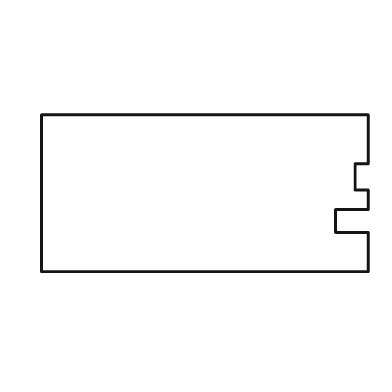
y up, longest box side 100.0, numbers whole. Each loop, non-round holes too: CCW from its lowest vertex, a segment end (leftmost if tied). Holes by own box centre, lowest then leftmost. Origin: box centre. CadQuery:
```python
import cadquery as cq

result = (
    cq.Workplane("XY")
    .moveTo(-50.0, -24.0)
    .lineTo(50.0, -24.0)
    .lineTo(50.0, -12.0)
    .lineTo(40.0, -12.0)
    .lineTo(40.0, -5.0)
    .lineTo(50.0, -5.0)
    .lineTo(50.0, 1.0)
    .lineTo(46.0, 1.0)
    .lineTo(46.0, 9.0)
    .lineTo(50.0, 9.0)
    .lineTo(50.0, 24.0)
    .lineTo(-50.0, 24.0)
    .close()
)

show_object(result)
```